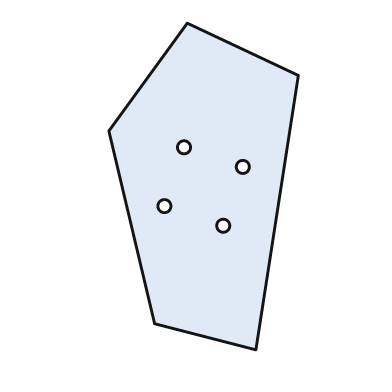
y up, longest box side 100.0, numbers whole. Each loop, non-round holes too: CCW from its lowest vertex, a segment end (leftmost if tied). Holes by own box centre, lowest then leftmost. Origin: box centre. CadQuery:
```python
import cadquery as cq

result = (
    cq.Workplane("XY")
    .moveTo(16.0, -50.0)
    .lineTo(29.0, 34.0)
    .lineTo(-5.0, 50.0)
    .lineTo(-29.0, 17.0)
    .lineTo(-15.0, -42.0)
    .close()
    .moveTo(6.0, -12.0)
    .circle(2.0)
    .moveTo(-12.0, -6.0)
    .circle(2.0)
    .moveTo(12.0, 6.0)
    .circle(2.0)
    .moveTo(-6.0, 12.0)
    .circle(2.0)
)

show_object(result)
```